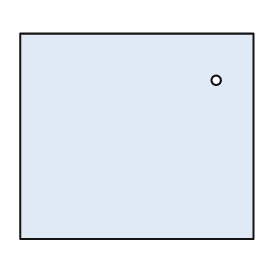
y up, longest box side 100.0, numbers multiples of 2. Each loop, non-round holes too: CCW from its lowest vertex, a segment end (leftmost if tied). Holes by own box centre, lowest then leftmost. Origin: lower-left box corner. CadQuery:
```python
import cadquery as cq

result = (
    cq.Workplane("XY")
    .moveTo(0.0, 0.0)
    .lineTo(100.0, 0.0)
    .lineTo(100.0, 88.0)
    .lineTo(0.0, 88.0)
    .close()
    .moveTo(84.0, 68.0)
    .circle(2.0)
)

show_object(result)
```